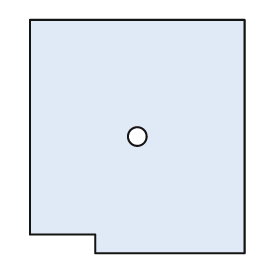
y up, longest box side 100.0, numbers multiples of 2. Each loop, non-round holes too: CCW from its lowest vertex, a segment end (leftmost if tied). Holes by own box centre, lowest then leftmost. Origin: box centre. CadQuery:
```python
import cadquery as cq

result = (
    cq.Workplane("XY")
    .moveTo(-18.0, -50.0)
    .lineTo(46.0, -50.0)
    .lineTo(46.0, 50.0)
    .lineTo(-46.0, 50.0)
    .lineTo(-46.0, -42.0)
    .lineTo(-18.0, -42.0)
    .close()
    .moveTo(0.0, 0.0)
    .circle(4.0)
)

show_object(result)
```